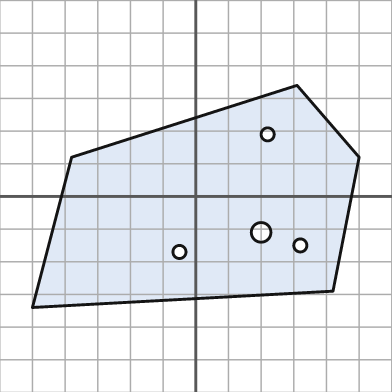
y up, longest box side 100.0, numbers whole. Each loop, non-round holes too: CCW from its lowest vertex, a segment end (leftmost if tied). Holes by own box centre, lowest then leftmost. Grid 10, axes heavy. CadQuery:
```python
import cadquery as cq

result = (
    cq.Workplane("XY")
    .moveTo(-50.0, -34.0)
    .lineTo(42.0, -29.0)
    .lineTo(50.0, 12.0)
    .lineTo(31.0, 34.0)
    .lineTo(-38.0, 12.0)
    .close()
    .moveTo(-5.0, -17.0)
    .circle(2.0)
    .moveTo(32.0, -15.0)
    .circle(2.0)
    .moveTo(20.0, -11.0)
    .circle(3.0)
    .moveTo(22.0, 19.0)
    .circle(2.0)
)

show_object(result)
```